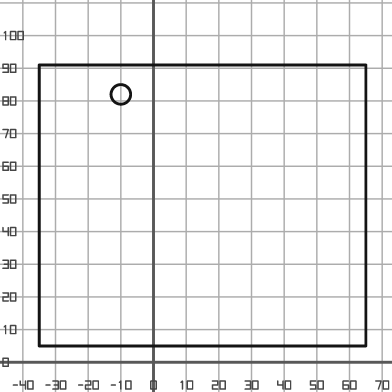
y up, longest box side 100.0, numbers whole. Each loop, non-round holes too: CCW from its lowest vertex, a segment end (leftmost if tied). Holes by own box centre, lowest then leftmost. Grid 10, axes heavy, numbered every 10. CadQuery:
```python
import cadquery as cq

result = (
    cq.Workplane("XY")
    .moveTo(-35.0, 5.0)
    .lineTo(65.0, 5.0)
    .lineTo(65.0, 91.0)
    .lineTo(-35.0, 91.0)
    .close()
    .moveTo(-10.0, 82.0)
    .circle(3.0)
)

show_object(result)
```